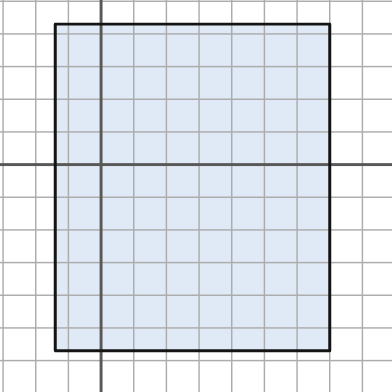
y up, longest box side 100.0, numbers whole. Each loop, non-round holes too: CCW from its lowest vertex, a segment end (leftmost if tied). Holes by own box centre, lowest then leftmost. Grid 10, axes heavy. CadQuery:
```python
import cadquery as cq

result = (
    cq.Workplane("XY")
    .moveTo(-14.0, -57.0)
    .lineTo(70.0, -57.0)
    .lineTo(70.0, 43.0)
    .lineTo(-14.0, 43.0)
    .close()
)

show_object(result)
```